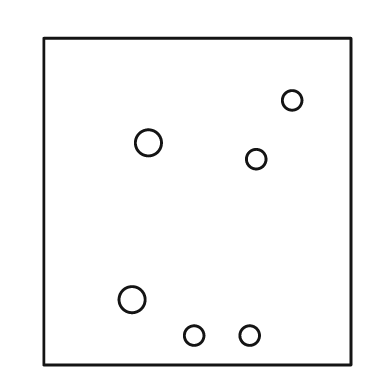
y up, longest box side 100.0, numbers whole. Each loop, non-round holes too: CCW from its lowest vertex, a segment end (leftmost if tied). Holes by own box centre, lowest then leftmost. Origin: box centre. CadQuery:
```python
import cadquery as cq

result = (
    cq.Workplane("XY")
    .moveTo(-47.0, -50.0)
    .lineTo(47.0, -50.0)
    .lineTo(47.0, 50.0)
    .lineTo(-47.0, 50.0)
    .close()
    .moveTo(-1.0, -41.0)
    .circle(3.0)
    .moveTo(16.0, -41.0)
    .circle(3.0)
    .moveTo(-20.0, -30.0)
    .circle(4.0)
    .moveTo(18.0, 13.0)
    .circle(3.0)
    .moveTo(-15.0, 18.0)
    .circle(4.0)
    .moveTo(29.0, 31.0)
    .circle(3.0)
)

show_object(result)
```